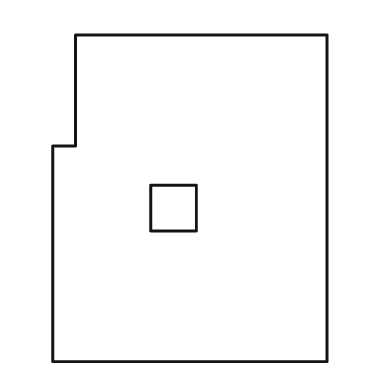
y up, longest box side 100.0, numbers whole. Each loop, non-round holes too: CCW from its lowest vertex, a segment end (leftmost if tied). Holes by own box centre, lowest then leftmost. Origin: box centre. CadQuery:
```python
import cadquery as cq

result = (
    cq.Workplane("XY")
    .moveTo(-42.0, -50.0)
    .lineTo(42.0, -50.0)
    .lineTo(42.0, 50.0)
    .lineTo(-35.0, 50.0)
    .lineTo(-35.0, 16.0)
    .lineTo(-42.0, 16.0)
    .close()
    .moveTo(-12.0, -10.0)
    .lineTo(2.0, -10.0)
    .lineTo(2.0, 4.0)
    .lineTo(-12.0, 4.0)
    .close()
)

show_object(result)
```